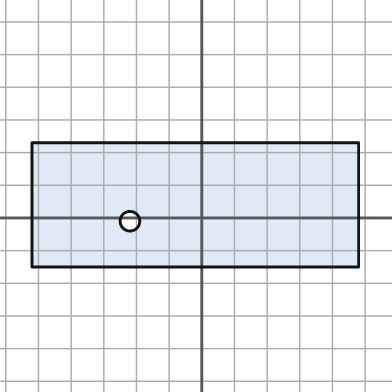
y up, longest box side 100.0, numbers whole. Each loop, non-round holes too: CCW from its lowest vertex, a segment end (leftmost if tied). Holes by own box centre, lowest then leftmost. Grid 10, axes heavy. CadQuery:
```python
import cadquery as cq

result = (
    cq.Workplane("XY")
    .moveTo(-52.0, -15.0)
    .lineTo(48.0, -15.0)
    .lineTo(48.0, 23.0)
    .lineTo(-52.0, 23.0)
    .close()
    .moveTo(-22.0, -1.0)
    .circle(3.0)
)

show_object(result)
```